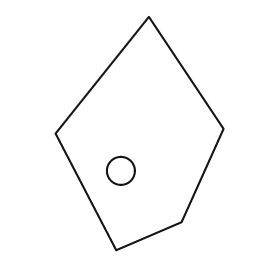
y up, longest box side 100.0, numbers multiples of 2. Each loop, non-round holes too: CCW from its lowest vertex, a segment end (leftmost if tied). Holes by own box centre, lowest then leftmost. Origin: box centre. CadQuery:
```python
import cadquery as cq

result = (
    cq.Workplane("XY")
    .moveTo(-10.0, -50.0)
    .lineTo(18.0, -38.0)
    .lineTo(36.0, 2.0)
    .lineTo(4.0, 50.0)
    .lineTo(-36.0, 0.0)
    .close()
    .moveTo(-8.0, -16.0)
    .circle(6.0)
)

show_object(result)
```